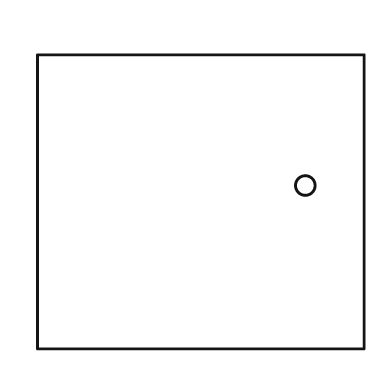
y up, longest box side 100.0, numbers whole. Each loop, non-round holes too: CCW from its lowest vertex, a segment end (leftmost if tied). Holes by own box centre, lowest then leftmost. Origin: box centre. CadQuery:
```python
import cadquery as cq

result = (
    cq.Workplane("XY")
    .moveTo(-50.0, -45.0)
    .lineTo(50.0, -45.0)
    .lineTo(50.0, 45.0)
    .lineTo(-50.0, 45.0)
    .close()
    .moveTo(32.0, 5.0)
    .circle(3.0)
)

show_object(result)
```